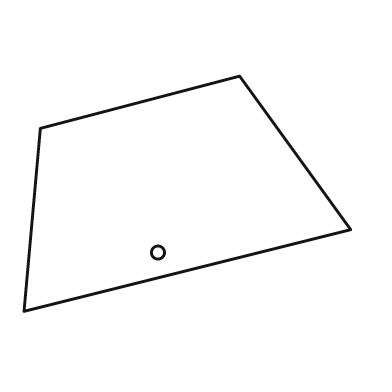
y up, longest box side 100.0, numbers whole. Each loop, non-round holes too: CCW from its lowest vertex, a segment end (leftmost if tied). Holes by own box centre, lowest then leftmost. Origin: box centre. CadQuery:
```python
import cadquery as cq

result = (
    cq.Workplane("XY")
    .moveTo(-50.0, -36.0)
    .lineTo(50.0, -11.0)
    .lineTo(16.0, 36.0)
    .lineTo(-45.0, 20.0)
    .close()
    .moveTo(-9.0, -18.0)
    .circle(2.0)
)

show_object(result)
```